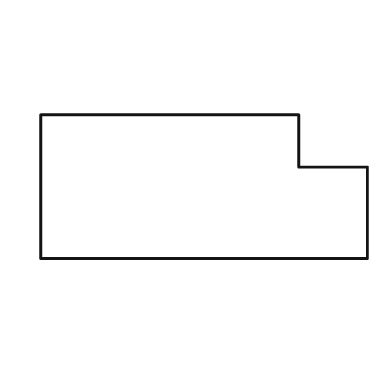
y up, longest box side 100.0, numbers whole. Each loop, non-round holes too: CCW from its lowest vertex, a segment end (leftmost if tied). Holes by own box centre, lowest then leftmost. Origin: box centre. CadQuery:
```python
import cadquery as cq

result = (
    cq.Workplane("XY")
    .moveTo(-50.0, -22.0)
    .lineTo(50.0, -22.0)
    .lineTo(50.0, 6.0)
    .lineTo(29.0, 6.0)
    .lineTo(29.0, 22.0)
    .lineTo(-50.0, 22.0)
    .close()
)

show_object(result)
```